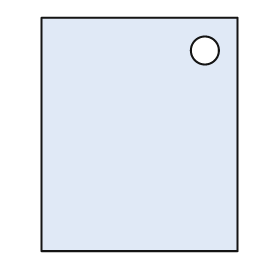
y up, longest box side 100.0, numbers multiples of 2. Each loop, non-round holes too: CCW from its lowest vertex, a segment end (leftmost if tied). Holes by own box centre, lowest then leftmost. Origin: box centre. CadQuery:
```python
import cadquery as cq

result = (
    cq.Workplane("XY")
    .moveTo(-42.0, -50.0)
    .lineTo(42.0, -50.0)
    .lineTo(42.0, 50.0)
    .lineTo(-42.0, 50.0)
    .close()
    .moveTo(28.0, 36.0)
    .circle(6.0)
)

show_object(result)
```